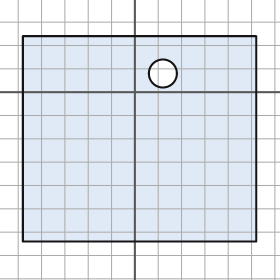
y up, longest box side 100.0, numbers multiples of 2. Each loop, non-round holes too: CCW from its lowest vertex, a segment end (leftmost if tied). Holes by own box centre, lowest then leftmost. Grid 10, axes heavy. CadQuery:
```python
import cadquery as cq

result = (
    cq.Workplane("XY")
    .moveTo(-48.0, -64.0)
    .lineTo(52.0, -64.0)
    .lineTo(52.0, 24.0)
    .lineTo(-48.0, 24.0)
    .close()
    .moveTo(12.0, 8.0)
    .circle(6.0)
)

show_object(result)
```